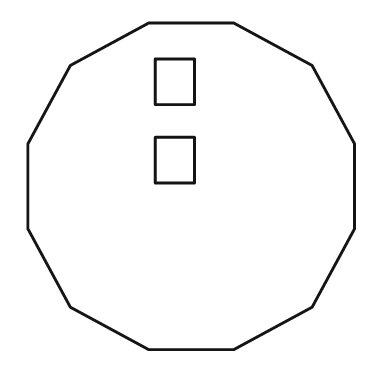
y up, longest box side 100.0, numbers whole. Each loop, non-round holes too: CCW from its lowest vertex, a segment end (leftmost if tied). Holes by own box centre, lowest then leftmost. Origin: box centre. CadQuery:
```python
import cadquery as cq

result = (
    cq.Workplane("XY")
    .moveTo(-13.0, -50.0)
    .lineTo(13.0, -50.0)
    .lineTo(37.0, -37.0)
    .lineTo(50.0, -13.0)
    .lineTo(50.0, 13.0)
    .lineTo(37.0, 37.0)
    .lineTo(13.0, 50.0)
    .lineTo(-13.0, 50.0)
    .lineTo(-37.0, 37.0)
    .lineTo(-50.0, 13.0)
    .lineTo(-50.0, -13.0)
    .lineTo(-37.0, -37.0)
    .close()
    .moveTo(-11.0, 1.0)
    .lineTo(1.0, 1.0)
    .lineTo(1.0, 15.0)
    .lineTo(-11.0, 15.0)
    .close()
    .moveTo(-11.0, 25.0)
    .lineTo(1.0, 25.0)
    .lineTo(1.0, 39.0)
    .lineTo(-11.0, 39.0)
    .close()
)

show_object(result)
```